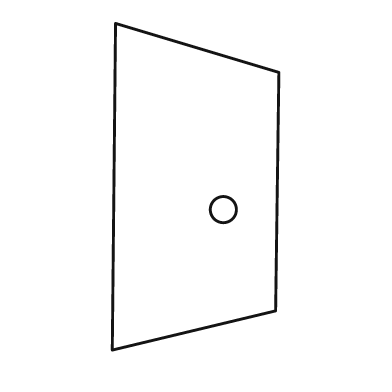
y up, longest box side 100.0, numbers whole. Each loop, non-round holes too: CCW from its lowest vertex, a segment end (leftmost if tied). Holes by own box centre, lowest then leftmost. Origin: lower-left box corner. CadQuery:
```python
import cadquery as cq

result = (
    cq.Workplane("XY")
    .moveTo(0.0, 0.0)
    .lineTo(50.0, 12.0)
    .lineTo(51.0, 85.0)
    .lineTo(1.0, 100.0)
    .close()
    .moveTo(34.0, 43.0)
    .circle(4.0)
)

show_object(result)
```